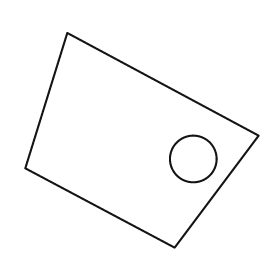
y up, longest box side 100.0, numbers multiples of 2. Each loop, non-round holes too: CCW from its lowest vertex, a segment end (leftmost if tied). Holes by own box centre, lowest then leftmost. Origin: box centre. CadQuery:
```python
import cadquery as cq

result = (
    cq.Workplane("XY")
    .moveTo(14.0, -46.0)
    .lineTo(50.0, 2.0)
    .lineTo(-32.0, 46.0)
    .lineTo(-50.0, -12.0)
    .close()
    .moveTo(22.0, -8.0)
    .circle(10.0)
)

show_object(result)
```